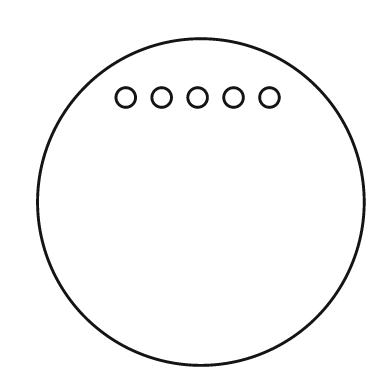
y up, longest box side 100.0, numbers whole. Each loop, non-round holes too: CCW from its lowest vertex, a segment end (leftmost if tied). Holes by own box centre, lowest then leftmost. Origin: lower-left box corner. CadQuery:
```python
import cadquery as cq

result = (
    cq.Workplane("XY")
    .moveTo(50.0, 50.0)
    .circle(50.0)
    .moveTo(27.0, 82.0)
    .circle(3.0)
    .moveTo(38.0, 82.0)
    .circle(3.0)
    .moveTo(49.0, 82.0)
    .circle(3.0)
    .moveTo(60.0, 82.0)
    .circle(3.0)
    .moveTo(71.0, 82.0)
    .circle(3.0)
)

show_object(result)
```